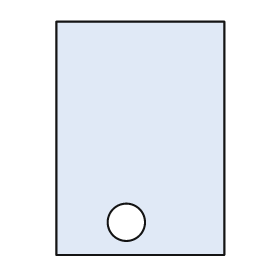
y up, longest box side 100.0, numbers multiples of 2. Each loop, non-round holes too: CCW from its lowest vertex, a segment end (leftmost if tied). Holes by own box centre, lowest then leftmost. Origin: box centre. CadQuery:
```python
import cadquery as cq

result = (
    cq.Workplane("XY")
    .moveTo(-36.0, -50.0)
    .lineTo(36.0, -50.0)
    .lineTo(36.0, 50.0)
    .lineTo(-36.0, 50.0)
    .close()
    .moveTo(-6.0, -36.0)
    .circle(8.0)
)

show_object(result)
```